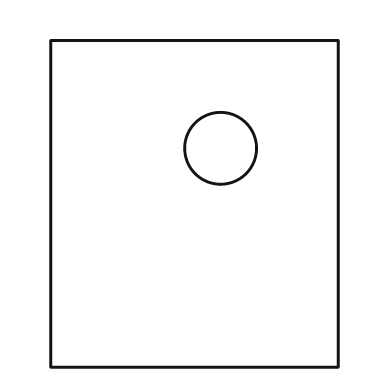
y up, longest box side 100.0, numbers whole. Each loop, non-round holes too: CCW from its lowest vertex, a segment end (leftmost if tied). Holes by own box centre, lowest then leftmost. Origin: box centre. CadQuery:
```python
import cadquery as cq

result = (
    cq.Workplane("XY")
    .moveTo(-44.0, -50.0)
    .lineTo(44.0, -50.0)
    .lineTo(44.0, 50.0)
    .lineTo(-44.0, 50.0)
    .close()
    .moveTo(8.0, 17.0)
    .circle(11.0)
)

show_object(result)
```